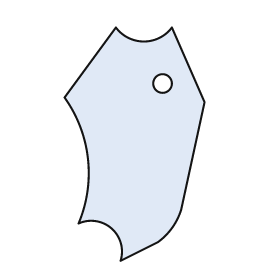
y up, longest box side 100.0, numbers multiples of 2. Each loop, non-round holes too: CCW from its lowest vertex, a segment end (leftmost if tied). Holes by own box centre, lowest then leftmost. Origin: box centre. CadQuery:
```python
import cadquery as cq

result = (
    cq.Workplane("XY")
    .moveTo(-6.0, -50.0)
    .lineTo(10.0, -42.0)
    .threePointArc((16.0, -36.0), (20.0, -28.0))
    .lineTo(30.0, 18.0)
    .lineTo(16.0, 50.0)
    .threePointArc((4.0, 44.0), (-8.0, 50.0))
    .lineTo(-30.0, 20.0)
    .threePointArc((-20.0, -6.0), (-24.0, -34.0))
    .threePointArc((-10.0, -36.0), (-6.0, -50.0))
    .close()
    .moveTo(12.0, 26.0)
    .circle(4.0)
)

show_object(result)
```